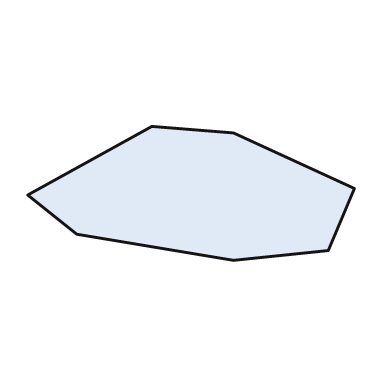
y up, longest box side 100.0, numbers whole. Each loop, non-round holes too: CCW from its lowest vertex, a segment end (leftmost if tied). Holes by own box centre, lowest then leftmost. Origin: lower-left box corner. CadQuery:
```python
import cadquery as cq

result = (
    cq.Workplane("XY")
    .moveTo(63.0, 0.0)
    .lineTo(92.0, 3.0)
    .lineTo(100.0, 22.0)
    .lineTo(63.0, 39.0)
    .lineTo(38.0, 41.0)
    .lineTo(0.0, 20.0)
    .lineTo(15.0, 8.0)
    .close()
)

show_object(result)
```